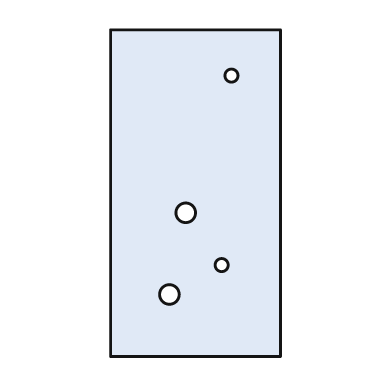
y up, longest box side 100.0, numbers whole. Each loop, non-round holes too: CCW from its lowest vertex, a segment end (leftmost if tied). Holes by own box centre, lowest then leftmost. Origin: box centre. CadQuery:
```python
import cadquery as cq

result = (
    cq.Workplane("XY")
    .moveTo(-26.0, -50.0)
    .lineTo(26.0, -50.0)
    .lineTo(26.0, 50.0)
    .lineTo(-26.0, 50.0)
    .close()
    .moveTo(-8.0, -31.0)
    .circle(3.0)
    .moveTo(8.0, -22.0)
    .circle(2.0)
    .moveTo(-3.0, -6.0)
    .circle(3.0)
    .moveTo(11.0, 36.0)
    .circle(2.0)
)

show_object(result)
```